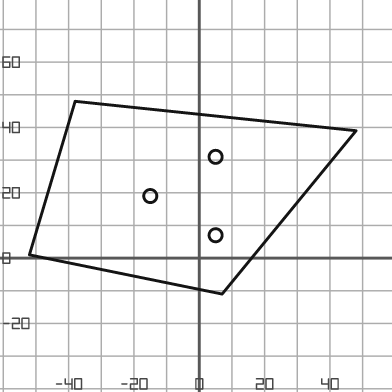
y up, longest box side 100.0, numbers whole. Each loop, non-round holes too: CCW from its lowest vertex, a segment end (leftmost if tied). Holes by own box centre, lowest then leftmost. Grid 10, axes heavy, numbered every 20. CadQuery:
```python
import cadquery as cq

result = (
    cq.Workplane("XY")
    .moveTo(7.0, -11.0)
    .lineTo(48.0, 39.0)
    .lineTo(-38.0, 48.0)
    .lineTo(-52.0, 1.0)
    .close()
    .moveTo(5.0, 7.0)
    .circle(2.0)
    .moveTo(-15.0, 19.0)
    .circle(2.0)
    .moveTo(5.0, 31.0)
    .circle(2.0)
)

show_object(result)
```